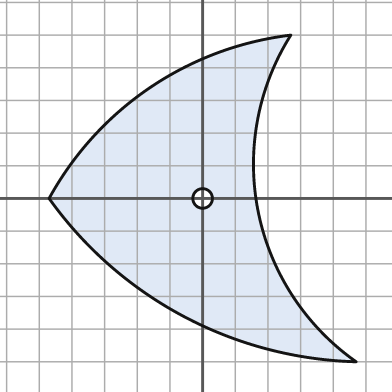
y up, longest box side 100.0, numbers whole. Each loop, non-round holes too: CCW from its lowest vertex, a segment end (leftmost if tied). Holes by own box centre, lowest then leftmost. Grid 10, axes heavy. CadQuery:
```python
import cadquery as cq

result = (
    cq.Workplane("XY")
    .moveTo(47.0, -50.0)
    .threePointArc((17.0, -4.0), (27.0, 50.0))
    .threePointArc((-16.0, 34.0), (-47.0, 0.0))
    .threePointArc((-6.0, -36.0), (47.0, -50.0))
    .close()
    .moveTo(0.0, 0.0)
    .circle(3.0)
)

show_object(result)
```